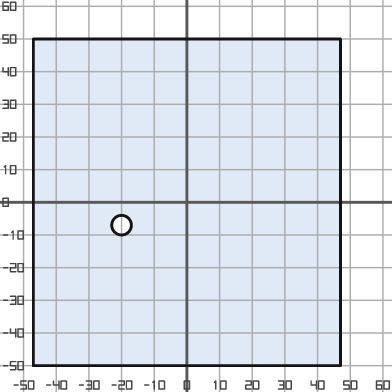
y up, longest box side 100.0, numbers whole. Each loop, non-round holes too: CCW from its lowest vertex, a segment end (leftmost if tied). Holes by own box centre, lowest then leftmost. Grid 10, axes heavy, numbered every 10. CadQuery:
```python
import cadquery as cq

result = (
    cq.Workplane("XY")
    .moveTo(-47.0, -50.0)
    .lineTo(47.0, -50.0)
    .lineTo(47.0, 50.0)
    .lineTo(-47.0, 50.0)
    .close()
    .moveTo(-20.0, -7.0)
    .circle(3.0)
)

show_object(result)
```